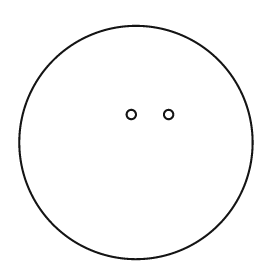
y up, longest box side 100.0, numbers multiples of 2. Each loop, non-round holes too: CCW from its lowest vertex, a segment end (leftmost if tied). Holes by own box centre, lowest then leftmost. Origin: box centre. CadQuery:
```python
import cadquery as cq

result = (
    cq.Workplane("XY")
    .moveTo(0.0, 0.0)
    .circle(50.0)
    .moveTo(-2.0, 12.0)
    .circle(2.0)
    .moveTo(14.0, 12.0)
    .circle(2.0)
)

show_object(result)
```